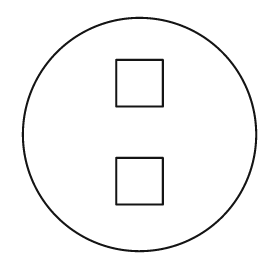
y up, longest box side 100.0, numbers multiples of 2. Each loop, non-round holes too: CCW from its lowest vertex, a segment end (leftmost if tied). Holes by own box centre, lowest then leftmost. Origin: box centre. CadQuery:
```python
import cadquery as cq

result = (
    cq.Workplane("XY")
    .moveTo(0.0, 0.0)
    .circle(50.0)
    .moveTo(-10.0, -30.0)
    .lineTo(10.0, -30.0)
    .lineTo(10.0, -10.0)
    .lineTo(-10.0, -10.0)
    .close()
    .moveTo(-10.0, 12.0)
    .lineTo(10.0, 12.0)
    .lineTo(10.0, 32.0)
    .lineTo(-10.0, 32.0)
    .close()
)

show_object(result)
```